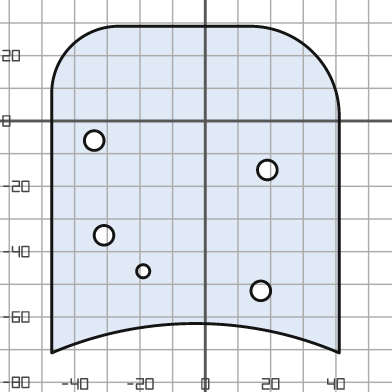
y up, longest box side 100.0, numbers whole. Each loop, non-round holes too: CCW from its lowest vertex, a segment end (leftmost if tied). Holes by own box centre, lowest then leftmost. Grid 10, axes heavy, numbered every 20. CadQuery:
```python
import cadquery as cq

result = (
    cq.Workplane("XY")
    .moveTo(-47.0, -71.0)
    .threePointArc((-3.0, -62.0), (41.0, -71.0))
    .lineTo(41.0, 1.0)
    .threePointArc((33.0, 21.0), (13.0, 29.0))
    .lineTo(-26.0, 29.0)
    .threePointArc((-41.0, 23.0), (-47.0, 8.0))
    .close()
    .moveTo(17.0, -52.0)
    .circle(3.0)
    .moveTo(-19.0, -46.0)
    .circle(2.0)
    .moveTo(-31.0, -35.0)
    .circle(3.0)
    .moveTo(19.0, -15.0)
    .circle(3.0)
    .moveTo(-34.0, -6.0)
    .circle(3.0)
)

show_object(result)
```